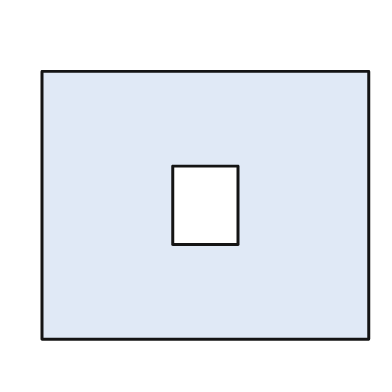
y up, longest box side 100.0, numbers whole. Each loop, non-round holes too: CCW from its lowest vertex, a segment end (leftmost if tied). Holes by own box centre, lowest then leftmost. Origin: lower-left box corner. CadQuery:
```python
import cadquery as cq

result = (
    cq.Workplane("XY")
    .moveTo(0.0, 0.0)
    .lineTo(100.0, 0.0)
    .lineTo(100.0, 82.0)
    .lineTo(0.0, 82.0)
    .close()
    .moveTo(40.0, 29.0)
    .lineTo(60.0, 29.0)
    .lineTo(60.0, 53.0)
    .lineTo(40.0, 53.0)
    .close()
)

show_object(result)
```